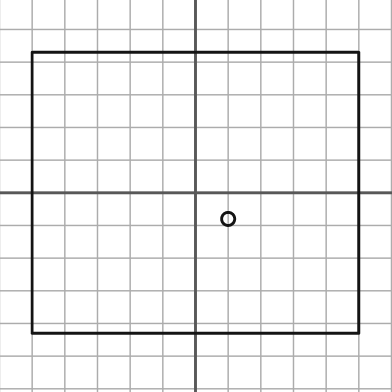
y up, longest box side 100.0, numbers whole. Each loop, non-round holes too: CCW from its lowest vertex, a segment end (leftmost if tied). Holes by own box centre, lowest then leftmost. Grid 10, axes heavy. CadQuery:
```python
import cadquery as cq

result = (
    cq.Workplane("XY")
    .moveTo(-50.0, -43.0)
    .lineTo(50.0, -43.0)
    .lineTo(50.0, 43.0)
    .lineTo(-50.0, 43.0)
    .close()
    .moveTo(10.0, -8.0)
    .circle(2.0)
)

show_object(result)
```